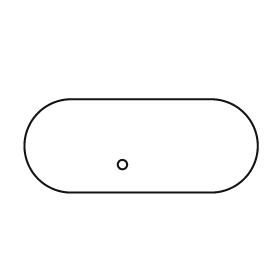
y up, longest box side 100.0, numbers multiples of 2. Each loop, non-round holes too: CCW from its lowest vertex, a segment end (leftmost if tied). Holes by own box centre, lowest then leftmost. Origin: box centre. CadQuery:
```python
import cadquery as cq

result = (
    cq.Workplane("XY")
    .moveTo(-30.0, -20.0)
    .lineTo(30.0, -20.0)
    .threePointArc((50.0, 0.0), (30.0, 20.0))
    .lineTo(-30.0, 20.0)
    .threePointArc((-50.0, 0.0), (-30.0, -20.0))
    .close()
    .moveTo(-8.0, -8.0)
    .circle(2.0)
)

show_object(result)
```